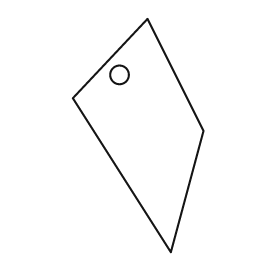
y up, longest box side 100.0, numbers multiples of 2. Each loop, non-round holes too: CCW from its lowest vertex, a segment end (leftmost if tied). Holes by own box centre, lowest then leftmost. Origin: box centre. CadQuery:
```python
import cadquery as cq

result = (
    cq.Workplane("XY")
    .moveTo(14.0, -50.0)
    .lineTo(28.0, 2.0)
    .lineTo(4.0, 50.0)
    .lineTo(-28.0, 16.0)
    .close()
    .moveTo(-8.0, 26.0)
    .circle(4.0)
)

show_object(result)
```